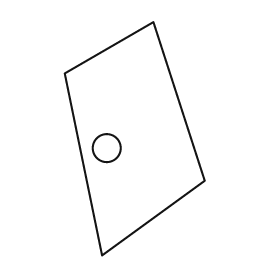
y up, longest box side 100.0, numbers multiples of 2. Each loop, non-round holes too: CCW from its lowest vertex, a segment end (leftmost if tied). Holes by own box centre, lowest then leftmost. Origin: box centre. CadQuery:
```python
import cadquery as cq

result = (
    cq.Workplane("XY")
    .moveTo(-14.0, -50.0)
    .lineTo(30.0, -18.0)
    .lineTo(8.0, 50.0)
    .lineTo(-30.0, 28.0)
    .close()
    .moveTo(-12.0, -4.0)
    .circle(6.0)
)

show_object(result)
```